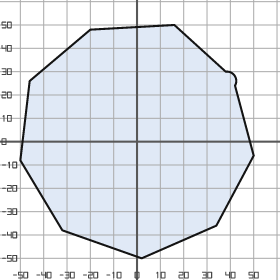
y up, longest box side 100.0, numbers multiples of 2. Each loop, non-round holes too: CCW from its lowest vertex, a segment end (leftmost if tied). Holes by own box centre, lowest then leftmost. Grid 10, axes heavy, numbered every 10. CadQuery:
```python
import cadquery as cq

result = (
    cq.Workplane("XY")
    .moveTo(2.0, -50.0)
    .lineTo(34.0, -36.0)
    .lineTo(50.0, -6.0)
    .lineTo(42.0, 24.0)
    .threePointArc((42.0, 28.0), (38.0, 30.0))
    .lineTo(16.0, 50.0)
    .lineTo(-20.0, 48.0)
    .lineTo(-46.0, 26.0)
    .lineTo(-50.0, -8.0)
    .lineTo(-32.0, -38.0)
    .close()
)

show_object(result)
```